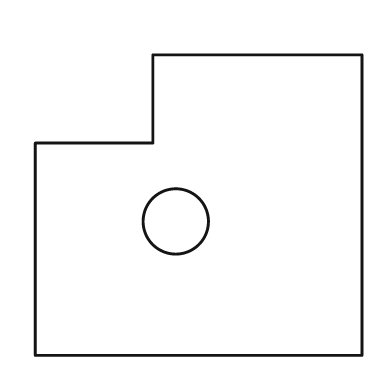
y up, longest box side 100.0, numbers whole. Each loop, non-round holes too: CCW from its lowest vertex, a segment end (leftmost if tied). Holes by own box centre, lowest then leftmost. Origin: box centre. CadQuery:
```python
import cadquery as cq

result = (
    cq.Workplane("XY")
    .moveTo(-50.0, -46.0)
    .lineTo(50.0, -46.0)
    .lineTo(50.0, 46.0)
    .lineTo(-14.0, 46.0)
    .lineTo(-14.0, 19.0)
    .lineTo(-50.0, 19.0)
    .close()
    .moveTo(-7.0, -5.0)
    .circle(10.0)
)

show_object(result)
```